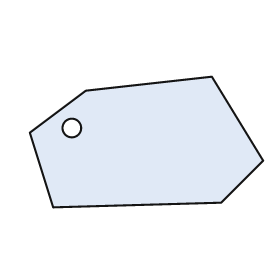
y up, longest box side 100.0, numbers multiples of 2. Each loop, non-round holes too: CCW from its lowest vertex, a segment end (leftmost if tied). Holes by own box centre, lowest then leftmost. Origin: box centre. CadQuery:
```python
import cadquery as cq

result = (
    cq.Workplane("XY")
    .moveTo(-40.0, -28.0)
    .lineTo(32.0, -26.0)
    .lineTo(50.0, -8.0)
    .lineTo(28.0, 28.0)
    .lineTo(-26.0, 22.0)
    .lineTo(-50.0, 4.0)
    .close()
    .moveTo(-32.0, 6.0)
    .circle(4.0)
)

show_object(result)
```